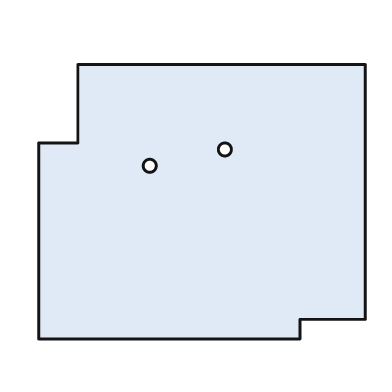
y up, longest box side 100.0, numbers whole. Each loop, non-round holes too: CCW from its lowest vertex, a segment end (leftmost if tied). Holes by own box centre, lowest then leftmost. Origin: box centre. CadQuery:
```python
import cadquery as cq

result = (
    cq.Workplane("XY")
    .moveTo(-50.0, -42.0)
    .lineTo(30.0, -42.0)
    .lineTo(30.0, -36.0)
    .lineTo(50.0, -36.0)
    .lineTo(50.0, 42.0)
    .lineTo(-38.0, 42.0)
    .lineTo(-38.0, 18.0)
    .lineTo(-50.0, 18.0)
    .close()
    .moveTo(-16.0, 11.0)
    .circle(2.0)
    .moveTo(7.0, 16.0)
    .circle(2.0)
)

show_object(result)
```